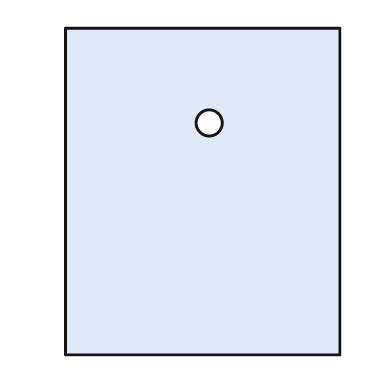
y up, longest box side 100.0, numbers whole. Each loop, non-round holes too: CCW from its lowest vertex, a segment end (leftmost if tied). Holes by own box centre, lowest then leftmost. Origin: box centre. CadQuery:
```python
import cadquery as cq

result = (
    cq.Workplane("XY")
    .moveTo(-42.0, -50.0)
    .lineTo(42.0, -50.0)
    .lineTo(42.0, 50.0)
    .lineTo(-42.0, 50.0)
    .close()
    .moveTo(2.0, 21.0)
    .circle(4.0)
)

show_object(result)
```